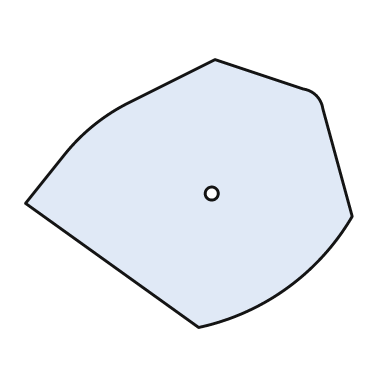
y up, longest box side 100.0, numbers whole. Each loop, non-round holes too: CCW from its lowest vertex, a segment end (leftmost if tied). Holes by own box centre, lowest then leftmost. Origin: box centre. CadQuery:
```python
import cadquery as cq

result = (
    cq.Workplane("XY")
    .moveTo(3.0, -41.0)
    .threePointArc((30.0, -29.0), (50.0, -7.0))
    .lineTo(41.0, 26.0)
    .threePointArc((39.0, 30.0), (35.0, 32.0))
    .lineTo(8.0, 41.0)
    .lineTo(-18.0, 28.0)
    .threePointArc((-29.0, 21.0), (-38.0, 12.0))
    .lineTo(-50.0, -3.0)
    .close()
    .moveTo(7.0, 0.0)
    .circle(2.0)
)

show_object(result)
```